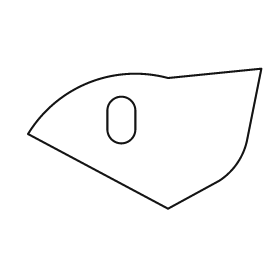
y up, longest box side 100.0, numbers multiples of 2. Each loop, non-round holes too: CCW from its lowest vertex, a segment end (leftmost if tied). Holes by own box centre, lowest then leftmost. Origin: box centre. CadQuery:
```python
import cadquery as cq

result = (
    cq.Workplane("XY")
    .moveTo(10.0, -30.0)
    .lineTo(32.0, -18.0)
    .threePointArc((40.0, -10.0), (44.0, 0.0))
    .lineTo(50.0, 30.0)
    .lineTo(10.0, 26.0)
    .threePointArc((-24.0, 24.0), (-50.0, 2.0))
    .close()
    .moveTo(-16.0, 4.0)
    .threePointArc((-10.0, -2.0), (-4.0, 4.0))
    .lineTo(-4.0, 12.0)
    .threePointArc((-10.0, 18.0), (-16.0, 12.0))
    .close()
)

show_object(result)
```